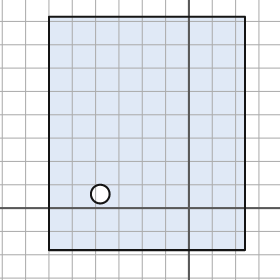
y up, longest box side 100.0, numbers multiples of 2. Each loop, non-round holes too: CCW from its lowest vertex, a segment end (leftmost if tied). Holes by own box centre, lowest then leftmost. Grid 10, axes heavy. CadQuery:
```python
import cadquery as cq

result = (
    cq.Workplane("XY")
    .moveTo(-60.0, -18.0)
    .lineTo(24.0, -18.0)
    .lineTo(24.0, 82.0)
    .lineTo(-60.0, 82.0)
    .close()
    .moveTo(-38.0, 6.0)
    .circle(4.0)
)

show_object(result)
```